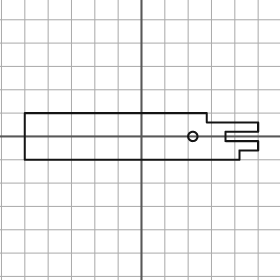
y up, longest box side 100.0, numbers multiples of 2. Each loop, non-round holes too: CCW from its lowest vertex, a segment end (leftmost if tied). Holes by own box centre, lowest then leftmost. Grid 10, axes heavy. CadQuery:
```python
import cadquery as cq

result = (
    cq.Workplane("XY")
    .moveTo(-50.0, -10.0)
    .lineTo(42.0, -10.0)
    .lineTo(42.0, -6.0)
    .lineTo(50.0, -6.0)
    .lineTo(50.0, -2.0)
    .lineTo(36.0, -2.0)
    .lineTo(36.0, 2.0)
    .lineTo(50.0, 2.0)
    .lineTo(50.0, 6.0)
    .lineTo(28.0, 6.0)
    .lineTo(28.0, 10.0)
    .lineTo(-50.0, 10.0)
    .close()
    .moveTo(22.0, 0.0)
    .circle(2.0)
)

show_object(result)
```